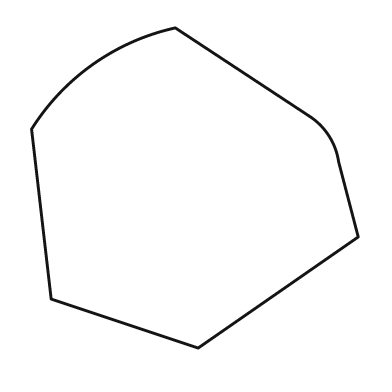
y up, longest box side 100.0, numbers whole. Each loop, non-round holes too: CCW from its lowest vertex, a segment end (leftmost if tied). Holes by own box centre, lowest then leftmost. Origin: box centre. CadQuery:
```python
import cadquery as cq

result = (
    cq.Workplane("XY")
    .moveTo(1.0, -49.0)
    .lineTo(50.0, -15.0)
    .lineTo(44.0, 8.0)
    .threePointArc((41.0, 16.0), (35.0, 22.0))
    .lineTo(-6.0, 49.0)
    .threePointArc((-31.0, 38.0), (-50.0, 18.0))
    .lineTo(-44.0, -34.0)
    .close()
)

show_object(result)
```